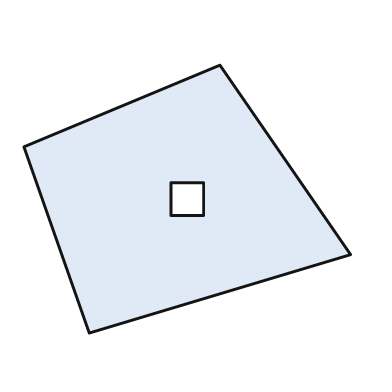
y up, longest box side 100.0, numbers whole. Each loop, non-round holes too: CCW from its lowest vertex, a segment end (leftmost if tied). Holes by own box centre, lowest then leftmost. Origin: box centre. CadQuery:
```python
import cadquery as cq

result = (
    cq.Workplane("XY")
    .moveTo(-30.0, -41.0)
    .lineTo(50.0, -17.0)
    .lineTo(10.0, 41.0)
    .lineTo(-50.0, 16.0)
    .close()
    .moveTo(-5.0, -5.0)
    .lineTo(5.0, -5.0)
    .lineTo(5.0, 5.0)
    .lineTo(-5.0, 5.0)
    .close()
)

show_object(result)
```